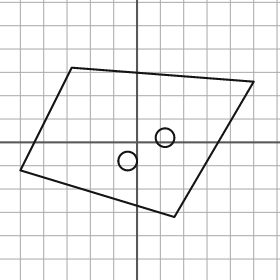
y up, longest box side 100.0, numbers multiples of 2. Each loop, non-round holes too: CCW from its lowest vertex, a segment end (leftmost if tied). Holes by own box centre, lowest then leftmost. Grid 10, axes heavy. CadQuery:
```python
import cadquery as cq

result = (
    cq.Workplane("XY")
    .moveTo(16.0, -32.0)
    .lineTo(50.0, 26.0)
    .lineTo(-28.0, 32.0)
    .lineTo(-50.0, -12.0)
    .close()
    .moveTo(-4.0, -8.0)
    .circle(4.0)
    .moveTo(12.0, 2.0)
    .circle(4.0)
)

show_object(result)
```